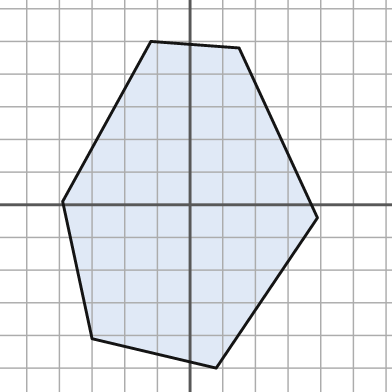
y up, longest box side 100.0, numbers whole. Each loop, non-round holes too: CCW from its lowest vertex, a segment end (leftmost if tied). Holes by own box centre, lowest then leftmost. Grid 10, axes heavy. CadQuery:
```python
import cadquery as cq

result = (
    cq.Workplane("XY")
    .moveTo(8.0, -50.0)
    .lineTo(39.0, -4.0)
    .lineTo(15.0, 48.0)
    .lineTo(-12.0, 50.0)
    .lineTo(-39.0, 1.0)
    .lineTo(-30.0, -41.0)
    .close()
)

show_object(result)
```